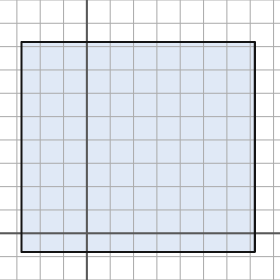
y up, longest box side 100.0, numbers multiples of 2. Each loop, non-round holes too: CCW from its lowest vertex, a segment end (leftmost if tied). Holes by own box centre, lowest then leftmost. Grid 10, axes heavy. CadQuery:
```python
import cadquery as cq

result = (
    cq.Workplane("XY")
    .moveTo(-28.0, -8.0)
    .lineTo(72.0, -8.0)
    .lineTo(72.0, 82.0)
    .lineTo(-28.0, 82.0)
    .close()
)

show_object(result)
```